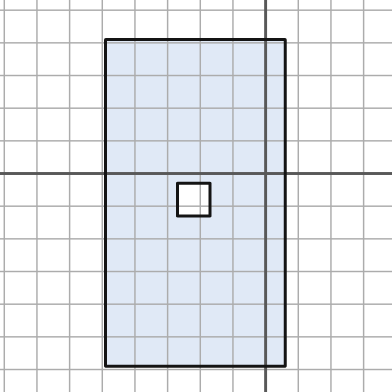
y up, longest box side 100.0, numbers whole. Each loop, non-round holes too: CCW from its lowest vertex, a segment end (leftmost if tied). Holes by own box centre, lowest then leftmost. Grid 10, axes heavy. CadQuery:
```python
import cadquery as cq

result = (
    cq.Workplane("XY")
    .moveTo(-49.0, -59.0)
    .lineTo(6.0, -59.0)
    .lineTo(6.0, 41.0)
    .lineTo(-49.0, 41.0)
    .close()
    .moveTo(-27.0, -13.0)
    .lineTo(-17.0, -13.0)
    .lineTo(-17.0, -3.0)
    .lineTo(-27.0, -3.0)
    .close()
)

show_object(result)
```